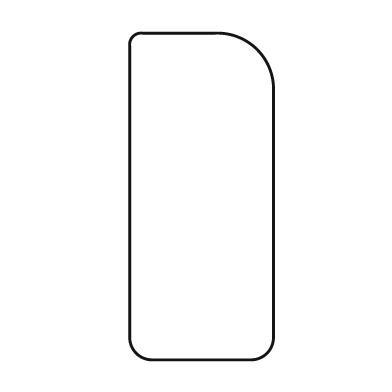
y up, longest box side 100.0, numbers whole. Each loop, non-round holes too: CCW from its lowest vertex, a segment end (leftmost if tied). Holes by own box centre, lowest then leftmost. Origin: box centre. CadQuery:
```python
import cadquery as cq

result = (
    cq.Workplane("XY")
    .moveTo(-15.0, -50.0)
    .lineTo(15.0, -50.0)
    .threePointArc((20.0, -48.0), (22.0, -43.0))
    .lineTo(22.0, 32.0)
    .threePointArc((17.0, 45.0), (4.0, 50.0))
    .lineTo(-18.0, 50.0)
    .threePointArc((-21.0, 49.0), (-22.0, 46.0))
    .lineTo(-22.0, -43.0)
    .threePointArc((-20.0, -48.0), (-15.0, -50.0))
    .close()
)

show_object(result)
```